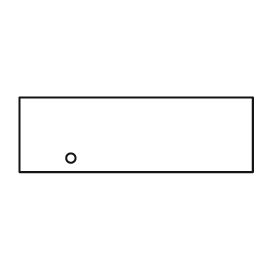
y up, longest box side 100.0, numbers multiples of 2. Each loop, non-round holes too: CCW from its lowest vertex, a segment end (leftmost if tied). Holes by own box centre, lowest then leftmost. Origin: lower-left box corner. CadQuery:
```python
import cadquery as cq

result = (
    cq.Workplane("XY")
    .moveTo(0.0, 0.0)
    .lineTo(100.0, 0.0)
    .lineTo(100.0, 32.0)
    .lineTo(0.0, 32.0)
    .close()
    .moveTo(22.0, 6.0)
    .circle(2.0)
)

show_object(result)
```